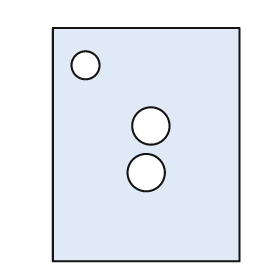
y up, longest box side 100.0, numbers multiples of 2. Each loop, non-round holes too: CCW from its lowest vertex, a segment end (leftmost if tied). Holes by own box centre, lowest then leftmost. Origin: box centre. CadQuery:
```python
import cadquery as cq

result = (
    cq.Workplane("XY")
    .moveTo(-40.0, -50.0)
    .lineTo(40.0, -50.0)
    .lineTo(40.0, 50.0)
    .lineTo(-40.0, 50.0)
    .close()
    .moveTo(0.0, -12.0)
    .circle(8.0)
    .moveTo(2.0, 8.0)
    .circle(8.0)
    .moveTo(-26.0, 34.0)
    .circle(6.0)
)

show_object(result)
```